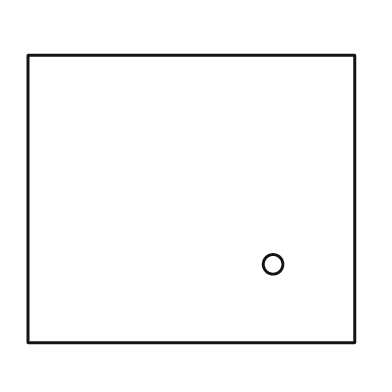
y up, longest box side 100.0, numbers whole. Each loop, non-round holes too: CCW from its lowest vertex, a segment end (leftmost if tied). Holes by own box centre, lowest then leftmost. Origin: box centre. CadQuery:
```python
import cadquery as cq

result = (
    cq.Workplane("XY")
    .moveTo(-50.0, -44.0)
    .lineTo(50.0, -44.0)
    .lineTo(50.0, 44.0)
    .lineTo(-50.0, 44.0)
    .close()
    .moveTo(25.0, -20.0)
    .circle(3.0)
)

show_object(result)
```